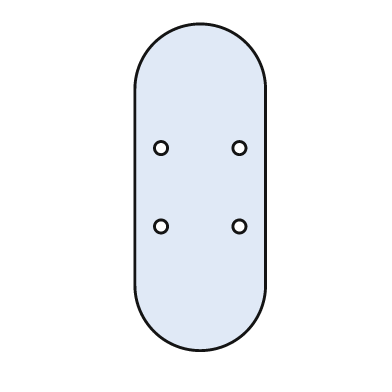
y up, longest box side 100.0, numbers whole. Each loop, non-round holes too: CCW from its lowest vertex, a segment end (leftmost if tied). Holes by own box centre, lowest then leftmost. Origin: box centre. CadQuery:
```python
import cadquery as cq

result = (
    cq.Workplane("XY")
    .moveTo(-20.0, -30.0)
    .threePointArc((0.0, -50.0), (20.0, -30.0))
    .lineTo(20.0, 30.0)
    .threePointArc((0.0, 50.0), (-20.0, 30.0))
    .close()
    .moveTo(-12.0, -12.0)
    .circle(2.0)
    .moveTo(12.0, -12.0)
    .circle(2.0)
    .moveTo(-12.0, 12.0)
    .circle(2.0)
    .moveTo(12.0, 12.0)
    .circle(2.0)
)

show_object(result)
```